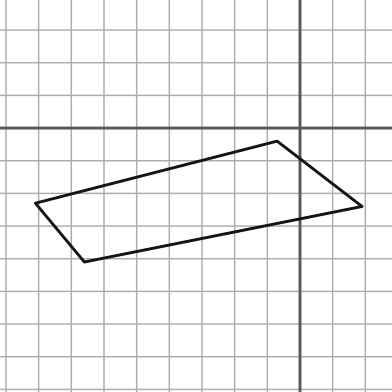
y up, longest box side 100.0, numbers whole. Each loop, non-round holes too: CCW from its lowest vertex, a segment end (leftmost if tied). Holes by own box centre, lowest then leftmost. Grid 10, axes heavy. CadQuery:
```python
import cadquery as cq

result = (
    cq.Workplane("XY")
    .moveTo(-66.0, -41.0)
    .lineTo(19.0, -24.0)
    .lineTo(-7.0, -4.0)
    .lineTo(-81.0, -23.0)
    .close()
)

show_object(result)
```